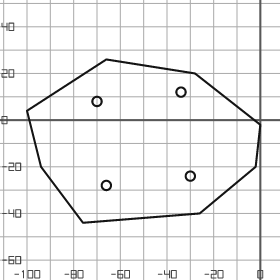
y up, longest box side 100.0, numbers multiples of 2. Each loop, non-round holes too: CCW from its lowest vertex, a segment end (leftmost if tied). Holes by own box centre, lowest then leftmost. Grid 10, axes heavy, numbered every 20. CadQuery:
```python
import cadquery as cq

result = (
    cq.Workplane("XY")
    .moveTo(-76.0, -44.0)
    .lineTo(-26.0, -40.0)
    .lineTo(-2.0, -20.0)
    .lineTo(0.0, -2.0)
    .lineTo(-28.0, 20.0)
    .lineTo(-66.0, 26.0)
    .lineTo(-100.0, 4.0)
    .lineTo(-94.0, -20.0)
    .close()
    .moveTo(-66.0, -28.0)
    .circle(2.0)
    .moveTo(-30.0, -24.0)
    .circle(2.0)
    .moveTo(-70.0, 8.0)
    .circle(2.0)
    .moveTo(-34.0, 12.0)
    .circle(2.0)
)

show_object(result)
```